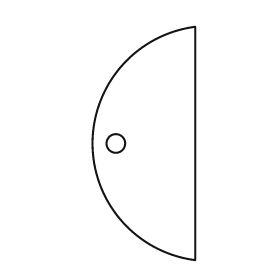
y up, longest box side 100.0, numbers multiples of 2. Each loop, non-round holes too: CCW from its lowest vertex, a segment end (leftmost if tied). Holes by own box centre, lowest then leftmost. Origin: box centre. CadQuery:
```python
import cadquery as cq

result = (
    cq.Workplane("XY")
    .moveTo(22.0, -50.0)
    .lineTo(22.0, 50.0)
    .threePointArc((-22.0, 0.0), (22.0, -50.0))
    .close()
    .moveTo(-12.0, 0.0)
    .circle(4.0)
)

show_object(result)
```